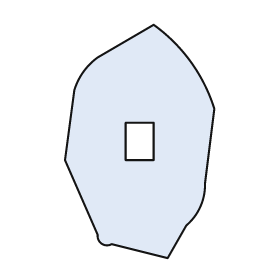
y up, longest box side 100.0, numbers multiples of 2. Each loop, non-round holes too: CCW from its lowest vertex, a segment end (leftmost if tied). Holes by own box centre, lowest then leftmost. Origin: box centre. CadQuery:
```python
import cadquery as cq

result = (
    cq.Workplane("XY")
    .moveTo(12.0, -50.0)
    .lineTo(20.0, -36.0)
    .threePointArc((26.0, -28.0), (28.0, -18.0))
    .lineTo(32.0, 14.0)
    .threePointArc((22.0, 34.0), (6.0, 50.0))
    .lineTo(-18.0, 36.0)
    .threePointArc((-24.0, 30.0), (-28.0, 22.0))
    .lineTo(-32.0, -8.0)
    .lineTo(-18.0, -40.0)
    .threePointArc((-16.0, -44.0), (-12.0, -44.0))
    .close()
    .moveTo(-6.0, -8.0)
    .lineTo(6.0, -8.0)
    .lineTo(6.0, 8.0)
    .lineTo(-6.0, 8.0)
    .close()
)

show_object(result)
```